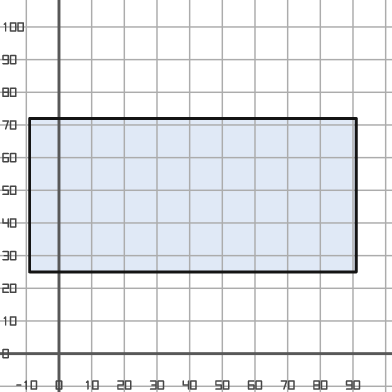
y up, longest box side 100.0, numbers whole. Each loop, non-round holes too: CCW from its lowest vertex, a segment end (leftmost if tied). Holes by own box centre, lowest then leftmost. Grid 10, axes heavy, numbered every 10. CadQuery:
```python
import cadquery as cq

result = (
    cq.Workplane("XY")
    .moveTo(-9.0, 25.0)
    .lineTo(91.0, 25.0)
    .lineTo(91.0, 72.0)
    .lineTo(-9.0, 72.0)
    .close()
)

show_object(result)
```